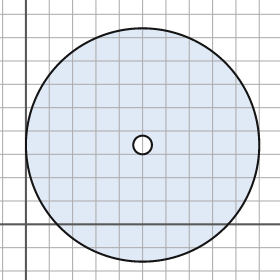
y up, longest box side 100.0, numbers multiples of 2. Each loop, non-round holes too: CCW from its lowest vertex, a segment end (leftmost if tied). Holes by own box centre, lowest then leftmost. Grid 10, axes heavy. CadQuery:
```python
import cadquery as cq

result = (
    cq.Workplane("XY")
    .moveTo(50.0, 34.0)
    .circle(50.0)
    .moveTo(50.0, 34.0)
    .circle(4.0)
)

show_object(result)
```